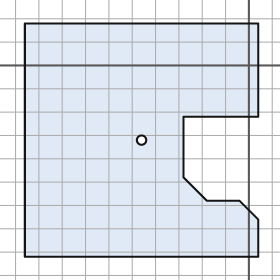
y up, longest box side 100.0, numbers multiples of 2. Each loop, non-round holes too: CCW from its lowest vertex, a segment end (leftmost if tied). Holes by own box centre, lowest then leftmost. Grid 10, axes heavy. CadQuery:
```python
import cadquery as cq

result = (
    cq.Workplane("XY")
    .moveTo(-96.0, -82.0)
    .lineTo(4.0, -82.0)
    .lineTo(4.0, -66.0)
    .lineTo(-4.0, -58.0)
    .lineTo(-18.0, -58.0)
    .lineTo(-28.0, -48.0)
    .lineTo(-28.0, -22.0)
    .lineTo(4.0, -22.0)
    .lineTo(4.0, 18.0)
    .lineTo(-96.0, 18.0)
    .close()
    .moveTo(-46.0, -32.0)
    .circle(2.0)
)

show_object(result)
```